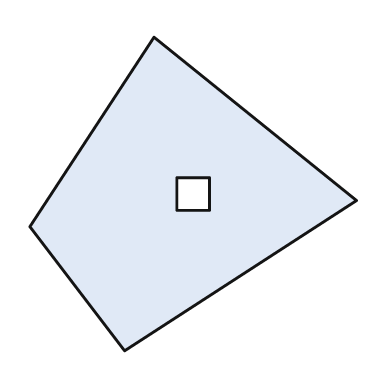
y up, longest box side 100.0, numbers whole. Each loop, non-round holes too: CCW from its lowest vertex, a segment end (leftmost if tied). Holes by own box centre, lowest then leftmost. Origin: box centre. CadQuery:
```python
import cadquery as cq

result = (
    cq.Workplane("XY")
    .moveTo(-21.0, -48.0)
    .lineTo(50.0, -2.0)
    .lineTo(-12.0, 48.0)
    .lineTo(-50.0, -10.0)
    .close()
    .moveTo(-5.0, -5.0)
    .lineTo(5.0, -5.0)
    .lineTo(5.0, 5.0)
    .lineTo(-5.0, 5.0)
    .close()
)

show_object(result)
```